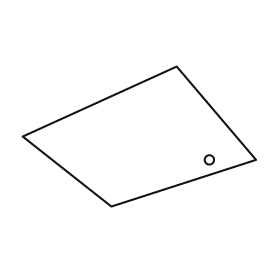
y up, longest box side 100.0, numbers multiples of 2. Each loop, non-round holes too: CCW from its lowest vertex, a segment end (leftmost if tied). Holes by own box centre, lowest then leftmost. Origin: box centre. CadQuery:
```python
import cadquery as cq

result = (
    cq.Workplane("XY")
    .moveTo(-12.0, -30.0)
    .lineTo(50.0, -10.0)
    .lineTo(16.0, 30.0)
    .lineTo(-50.0, 0.0)
    .close()
    .moveTo(30.0, -10.0)
    .circle(2.0)
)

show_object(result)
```